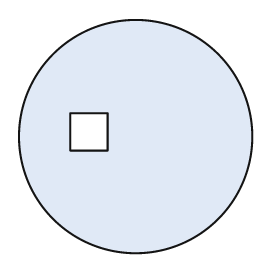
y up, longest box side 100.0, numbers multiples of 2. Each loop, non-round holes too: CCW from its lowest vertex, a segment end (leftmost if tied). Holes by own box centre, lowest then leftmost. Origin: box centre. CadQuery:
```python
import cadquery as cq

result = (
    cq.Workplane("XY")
    .moveTo(0.0, 0.0)
    .circle(50.0)
    .moveTo(-28.0, -6.0)
    .lineTo(-12.0, -6.0)
    .lineTo(-12.0, 10.0)
    .lineTo(-28.0, 10.0)
    .close()
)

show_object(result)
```